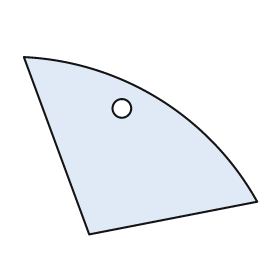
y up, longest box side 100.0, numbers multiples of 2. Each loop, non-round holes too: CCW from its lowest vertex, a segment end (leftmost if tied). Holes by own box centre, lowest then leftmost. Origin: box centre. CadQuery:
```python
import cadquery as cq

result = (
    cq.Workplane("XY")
    .moveTo(-22.0, -38.0)
    .lineTo(50.0, -24.0)
    .threePointArc((8.0, 20.0), (-50.0, 38.0))
    .close()
    .moveTo(-8.0, 16.0)
    .circle(4.0)
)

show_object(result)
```